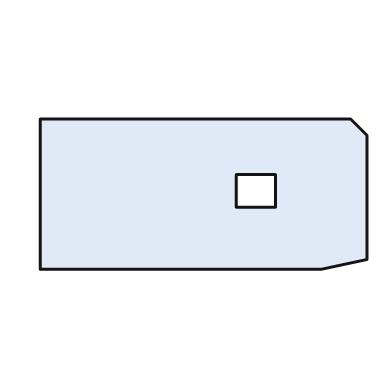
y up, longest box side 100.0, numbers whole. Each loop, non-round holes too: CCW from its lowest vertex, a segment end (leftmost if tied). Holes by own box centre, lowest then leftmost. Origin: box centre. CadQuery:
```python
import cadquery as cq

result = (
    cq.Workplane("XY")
    .moveTo(-50.0, -23.0)
    .lineTo(36.0, -23.0)
    .lineTo(50.0, -20.0)
    .lineTo(50.0, 18.0)
    .lineTo(45.0, 23.0)
    .lineTo(-50.0, 23.0)
    .close()
    .moveTo(10.0, -4.0)
    .lineTo(22.0, -4.0)
    .lineTo(22.0, 6.0)
    .lineTo(10.0, 6.0)
    .close()
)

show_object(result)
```